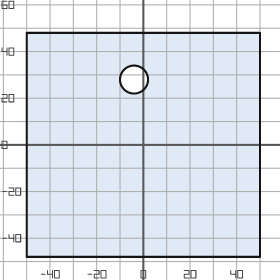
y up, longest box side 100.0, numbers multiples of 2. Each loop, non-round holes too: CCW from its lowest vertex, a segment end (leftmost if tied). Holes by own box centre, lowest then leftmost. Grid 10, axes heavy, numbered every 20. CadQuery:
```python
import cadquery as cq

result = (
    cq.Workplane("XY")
    .moveTo(-50.0, -48.0)
    .lineTo(50.0, -48.0)
    .lineTo(50.0, 48.0)
    .lineTo(-50.0, 48.0)
    .close()
    .moveTo(-4.0, 28.0)
    .circle(6.0)
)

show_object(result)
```